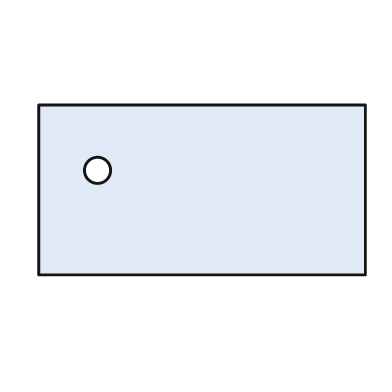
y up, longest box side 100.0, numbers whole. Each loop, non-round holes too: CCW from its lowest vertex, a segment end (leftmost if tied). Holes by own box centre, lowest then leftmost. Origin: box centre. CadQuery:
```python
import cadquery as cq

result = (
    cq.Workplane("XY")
    .moveTo(-50.0, -26.0)
    .lineTo(50.0, -26.0)
    .lineTo(50.0, 26.0)
    .lineTo(-50.0, 26.0)
    .close()
    .moveTo(-32.0, 6.0)
    .circle(4.0)
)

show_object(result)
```